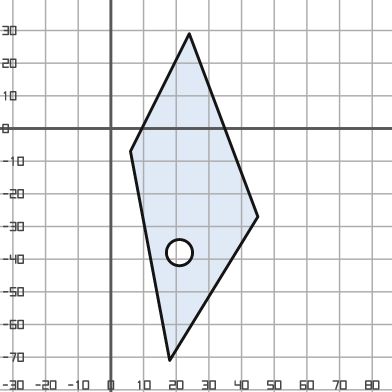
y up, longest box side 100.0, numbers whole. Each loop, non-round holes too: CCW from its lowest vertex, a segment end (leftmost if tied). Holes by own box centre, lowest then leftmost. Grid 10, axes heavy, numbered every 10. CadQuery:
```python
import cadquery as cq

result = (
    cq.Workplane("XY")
    .moveTo(18.0, -71.0)
    .lineTo(45.0, -27.0)
    .lineTo(24.0, 29.0)
    .lineTo(6.0, -7.0)
    .close()
    .moveTo(21.0, -38.0)
    .circle(4.0)
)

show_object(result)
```